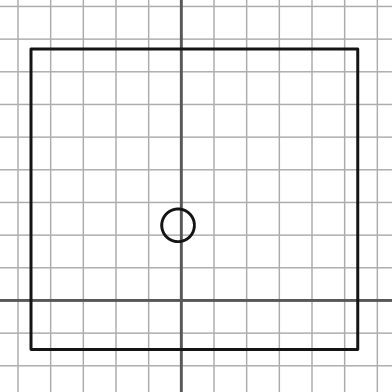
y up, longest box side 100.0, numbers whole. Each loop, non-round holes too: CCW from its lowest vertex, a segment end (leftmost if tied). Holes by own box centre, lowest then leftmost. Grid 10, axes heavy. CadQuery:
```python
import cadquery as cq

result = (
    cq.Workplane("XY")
    .moveTo(-46.0, -15.0)
    .lineTo(54.0, -15.0)
    .lineTo(54.0, 77.0)
    .lineTo(-46.0, 77.0)
    .close()
    .moveTo(-1.0, 23.0)
    .circle(5.0)
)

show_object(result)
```